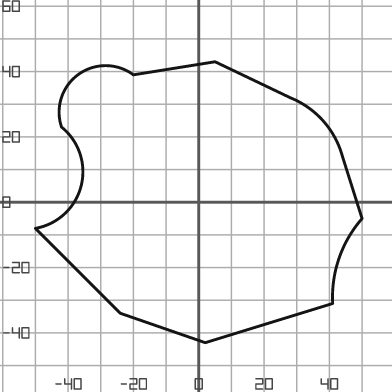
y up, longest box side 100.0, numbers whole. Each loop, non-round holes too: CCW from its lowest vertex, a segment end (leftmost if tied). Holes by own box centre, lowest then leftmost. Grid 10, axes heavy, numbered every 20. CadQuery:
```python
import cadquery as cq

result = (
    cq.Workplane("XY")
    .moveTo(2.0, -43.0)
    .lineTo(41.0, -31.0)
    .threePointArc((43.0, -17.0), (50.0, -5.0))
    .lineTo(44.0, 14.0)
    .threePointArc((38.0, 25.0), (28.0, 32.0))
    .lineTo(5.0, 43.0)
    .lineTo(-20.0, 39.0)
    .threePointArc((-37.0, 39.0), (-42.0, 23.0))
    .threePointArc((-36.0, 5.0), (-50.0, -8.0))
    .lineTo(-24.0, -34.0)
    .close()
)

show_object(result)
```